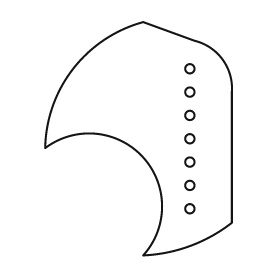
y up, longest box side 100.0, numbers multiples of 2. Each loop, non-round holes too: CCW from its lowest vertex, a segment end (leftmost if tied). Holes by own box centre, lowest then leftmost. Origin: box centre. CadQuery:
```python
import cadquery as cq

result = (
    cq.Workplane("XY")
    .moveTo(2.0, -50.0)
    .threePointArc((22.0, -46.0), (40.0, -36.0))
    .lineTo(40.0, 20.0)
    .threePointArc((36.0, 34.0), (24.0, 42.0))
    .lineTo(2.0, 50.0)
    .threePointArc((-28.0, 30.0), (-40.0, -4.0))
    .threePointArc((2.0, -8.0), (2.0, -50.0))
    .close()
    .moveTo(22.0, -30.0)
    .circle(2.0)
    .moveTo(22.0, -20.0)
    .circle(2.0)
    .moveTo(22.0, -10.0)
    .circle(2.0)
    .moveTo(22.0, 0.0)
    .circle(2.0)
    .moveTo(22.0, 10.0)
    .circle(2.0)
    .moveTo(22.0, 20.0)
    .circle(2.0)
    .moveTo(22.0, 30.0)
    .circle(2.0)
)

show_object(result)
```